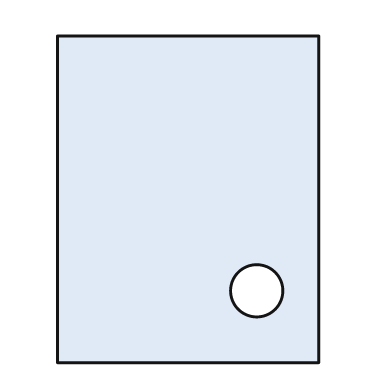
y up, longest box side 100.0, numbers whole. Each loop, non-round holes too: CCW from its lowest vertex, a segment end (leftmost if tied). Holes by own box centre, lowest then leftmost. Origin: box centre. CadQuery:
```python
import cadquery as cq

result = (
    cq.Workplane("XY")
    .moveTo(-40.0, -50.0)
    .lineTo(40.0, -50.0)
    .lineTo(40.0, 50.0)
    .lineTo(-40.0, 50.0)
    .close()
    .moveTo(21.0, -28.0)
    .circle(8.0)
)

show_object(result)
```